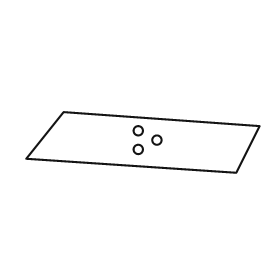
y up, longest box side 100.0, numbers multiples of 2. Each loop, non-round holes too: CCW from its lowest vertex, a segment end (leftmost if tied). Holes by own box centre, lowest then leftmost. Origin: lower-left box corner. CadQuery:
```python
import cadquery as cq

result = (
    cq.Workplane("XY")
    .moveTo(90.0, 0.0)
    .lineTo(100.0, 20.0)
    .lineTo(16.0, 26.0)
    .lineTo(0.0, 6.0)
    .close()
    .moveTo(48.0, 10.0)
    .circle(2.0)
    .moveTo(56.0, 14.0)
    .circle(2.0)
    .moveTo(48.0, 18.0)
    .circle(2.0)
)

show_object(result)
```